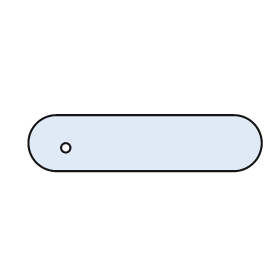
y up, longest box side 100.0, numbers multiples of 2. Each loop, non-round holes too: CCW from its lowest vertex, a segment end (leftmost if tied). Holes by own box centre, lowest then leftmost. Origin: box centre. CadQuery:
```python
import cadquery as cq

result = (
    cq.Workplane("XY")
    .moveTo(-38.0, -12.0)
    .lineTo(38.0, -12.0)
    .threePointArc((50.0, 0.0), (38.0, 12.0))
    .lineTo(-38.0, 12.0)
    .threePointArc((-50.0, 0.0), (-38.0, -12.0))
    .close()
    .moveTo(-34.0, -2.0)
    .circle(2.0)
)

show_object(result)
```